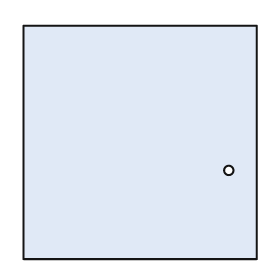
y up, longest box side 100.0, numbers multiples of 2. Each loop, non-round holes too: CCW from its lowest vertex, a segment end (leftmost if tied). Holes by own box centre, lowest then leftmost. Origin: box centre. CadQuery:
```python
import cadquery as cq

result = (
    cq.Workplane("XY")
    .moveTo(-50.0, -50.0)
    .lineTo(50.0, -50.0)
    .lineTo(50.0, 50.0)
    .lineTo(-50.0, 50.0)
    .close()
    .moveTo(38.0, -12.0)
    .circle(2.0)
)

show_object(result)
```